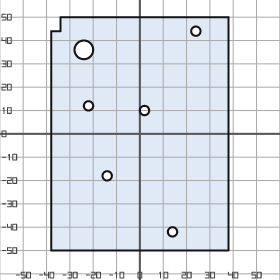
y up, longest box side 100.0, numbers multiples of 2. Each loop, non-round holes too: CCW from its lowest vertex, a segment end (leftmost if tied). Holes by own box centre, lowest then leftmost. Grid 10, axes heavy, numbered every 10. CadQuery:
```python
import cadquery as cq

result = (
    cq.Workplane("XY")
    .moveTo(-38.0, -50.0)
    .lineTo(38.0, -50.0)
    .lineTo(38.0, 50.0)
    .lineTo(-34.0, 50.0)
    .lineTo(-34.0, 44.0)
    .lineTo(-38.0, 44.0)
    .close()
    .moveTo(14.0, -42.0)
    .circle(2.0)
    .moveTo(-14.0, -18.0)
    .circle(2.0)
    .moveTo(2.0, 10.0)
    .circle(2.0)
    .moveTo(-22.0, 12.0)
    .circle(2.0)
    .moveTo(-24.0, 36.0)
    .circle(4.0)
    .moveTo(24.0, 44.0)
    .circle(2.0)
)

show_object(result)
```